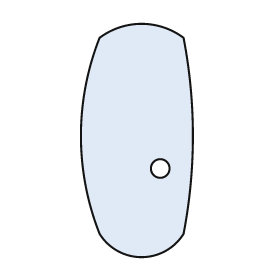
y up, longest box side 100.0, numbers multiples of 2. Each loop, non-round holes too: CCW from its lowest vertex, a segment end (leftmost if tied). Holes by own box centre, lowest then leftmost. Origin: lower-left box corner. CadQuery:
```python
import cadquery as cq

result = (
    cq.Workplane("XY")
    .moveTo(8.0, 10.0)
    .threePointArc((26.0, 0.0), (44.0, 10.0))
    .threePointArc((48.0, 52.0), (44.0, 94.0))
    .threePointArc((26.0, 100.0), (8.0, 94.0))
    .threePointArc((0.0, 52.0), (8.0, 10.0))
    .close()
    .moveTo(34.0, 38.0)
    .circle(4.0)
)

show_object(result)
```